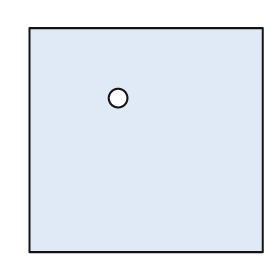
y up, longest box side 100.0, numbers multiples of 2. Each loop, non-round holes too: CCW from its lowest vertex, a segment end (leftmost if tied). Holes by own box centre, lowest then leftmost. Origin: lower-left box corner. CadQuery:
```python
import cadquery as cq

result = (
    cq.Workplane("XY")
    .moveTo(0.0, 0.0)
    .lineTo(100.0, 0.0)
    .lineTo(100.0, 96.0)
    .lineTo(0.0, 96.0)
    .close()
    .moveTo(38.0, 66.0)
    .circle(4.0)
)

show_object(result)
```